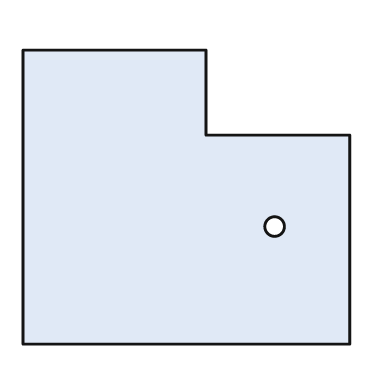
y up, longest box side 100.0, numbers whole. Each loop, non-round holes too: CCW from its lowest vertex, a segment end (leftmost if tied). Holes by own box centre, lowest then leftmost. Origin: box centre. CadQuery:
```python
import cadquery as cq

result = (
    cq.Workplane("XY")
    .moveTo(-50.0, -45.0)
    .lineTo(50.0, -45.0)
    .lineTo(50.0, 19.0)
    .lineTo(6.0, 19.0)
    .lineTo(6.0, 45.0)
    .lineTo(-50.0, 45.0)
    .close()
    .moveTo(27.0, -9.0)
    .circle(3.0)
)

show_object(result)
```